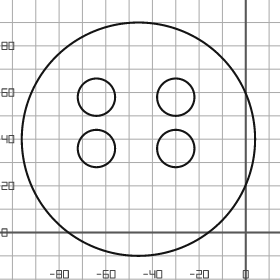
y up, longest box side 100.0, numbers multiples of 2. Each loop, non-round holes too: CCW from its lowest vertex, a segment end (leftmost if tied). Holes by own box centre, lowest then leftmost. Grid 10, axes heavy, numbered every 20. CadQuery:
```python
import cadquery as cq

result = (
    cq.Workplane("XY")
    .moveTo(-46.0, 40.0)
    .circle(50.0)
    .moveTo(-64.0, 36.0)
    .circle(8.0)
    .moveTo(-30.0, 36.0)
    .circle(8.0)
    .moveTo(-64.0, 58.0)
    .circle(8.0)
    .moveTo(-30.0, 58.0)
    .circle(8.0)
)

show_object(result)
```